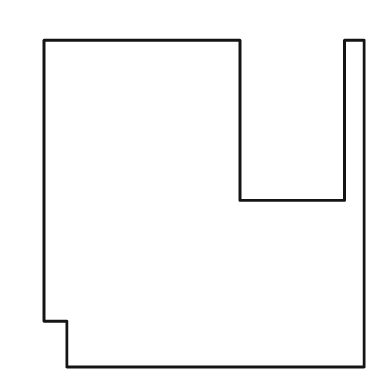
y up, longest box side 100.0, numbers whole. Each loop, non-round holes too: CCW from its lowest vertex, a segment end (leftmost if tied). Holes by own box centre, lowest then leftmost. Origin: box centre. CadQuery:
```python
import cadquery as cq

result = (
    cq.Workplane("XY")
    .moveTo(-42.0, -50.0)
    .lineTo(49.0, -50.0)
    .lineTo(49.0, 50.0)
    .lineTo(43.0, 50.0)
    .lineTo(43.0, 1.0)
    .lineTo(11.0, 1.0)
    .lineTo(11.0, 50.0)
    .lineTo(-49.0, 50.0)
    .lineTo(-49.0, -36.0)
    .lineTo(-42.0, -36.0)
    .close()
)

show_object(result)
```